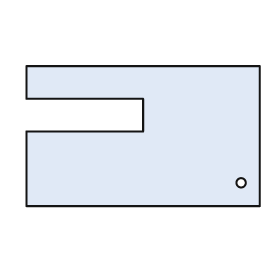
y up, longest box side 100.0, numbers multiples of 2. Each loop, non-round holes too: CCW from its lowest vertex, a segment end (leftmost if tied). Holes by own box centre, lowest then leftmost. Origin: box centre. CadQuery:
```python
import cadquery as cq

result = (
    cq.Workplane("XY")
    .moveTo(-50.0, -30.0)
    .lineTo(50.0, -30.0)
    .lineTo(50.0, 30.0)
    .lineTo(-50.0, 30.0)
    .lineTo(-50.0, 16.0)
    .lineTo(0.0, 16.0)
    .lineTo(0.0, 2.0)
    .lineTo(-50.0, 2.0)
    .close()
    .moveTo(42.0, -20.0)
    .circle(2.0)
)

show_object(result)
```